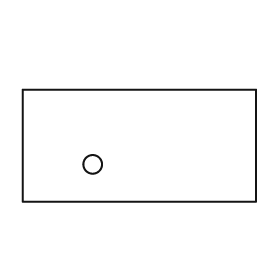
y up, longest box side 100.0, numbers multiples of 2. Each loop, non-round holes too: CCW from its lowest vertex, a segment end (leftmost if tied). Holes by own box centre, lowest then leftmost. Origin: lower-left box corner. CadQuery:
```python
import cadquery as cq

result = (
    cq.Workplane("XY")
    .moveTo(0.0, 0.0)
    .lineTo(100.0, 0.0)
    .lineTo(100.0, 48.0)
    .lineTo(0.0, 48.0)
    .close()
    .moveTo(30.0, 16.0)
    .circle(4.0)
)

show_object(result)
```